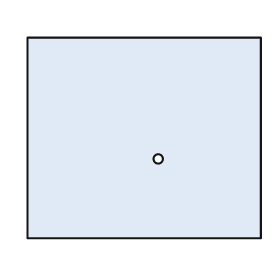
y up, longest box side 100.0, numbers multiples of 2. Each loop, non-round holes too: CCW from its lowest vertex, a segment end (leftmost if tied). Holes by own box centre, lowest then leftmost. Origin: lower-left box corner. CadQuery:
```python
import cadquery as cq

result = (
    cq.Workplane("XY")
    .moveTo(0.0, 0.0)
    .lineTo(100.0, 0.0)
    .lineTo(100.0, 86.0)
    .lineTo(0.0, 86.0)
    .close()
    .moveTo(56.0, 34.0)
    .circle(2.0)
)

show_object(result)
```